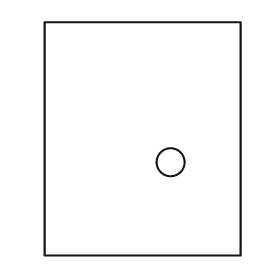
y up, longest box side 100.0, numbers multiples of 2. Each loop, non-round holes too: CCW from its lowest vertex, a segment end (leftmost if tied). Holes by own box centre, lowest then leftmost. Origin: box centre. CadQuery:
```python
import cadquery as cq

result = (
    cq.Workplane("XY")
    .moveTo(-42.0, -50.0)
    .lineTo(42.0, -50.0)
    .lineTo(42.0, 50.0)
    .lineTo(-42.0, 50.0)
    .close()
    .moveTo(12.0, -10.0)
    .circle(6.0)
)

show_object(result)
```